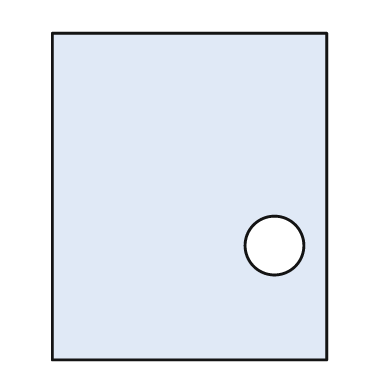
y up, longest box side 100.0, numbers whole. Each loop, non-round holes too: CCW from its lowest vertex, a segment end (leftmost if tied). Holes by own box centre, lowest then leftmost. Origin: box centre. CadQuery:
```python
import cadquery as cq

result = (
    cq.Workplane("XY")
    .moveTo(-42.0, -50.0)
    .lineTo(42.0, -50.0)
    .lineTo(42.0, 50.0)
    .lineTo(-42.0, 50.0)
    .close()
    .moveTo(26.0, -15.0)
    .circle(9.0)
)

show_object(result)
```